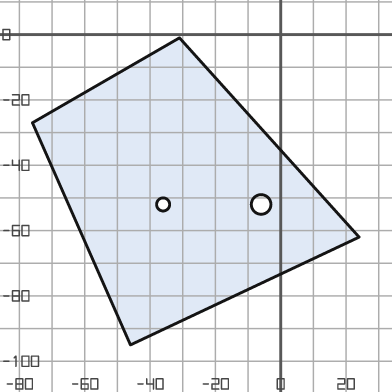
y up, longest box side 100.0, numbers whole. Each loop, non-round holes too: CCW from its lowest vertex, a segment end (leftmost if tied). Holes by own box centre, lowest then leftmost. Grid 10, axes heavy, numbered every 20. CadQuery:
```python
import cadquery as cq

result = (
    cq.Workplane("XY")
    .moveTo(-46.0, -95.0)
    .lineTo(24.0, -62.0)
    .lineTo(-31.0, -1.0)
    .lineTo(-76.0, -27.0)
    .close()
    .moveTo(-36.0, -52.0)
    .circle(2.0)
    .moveTo(-6.0, -52.0)
    .circle(3.0)
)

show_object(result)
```